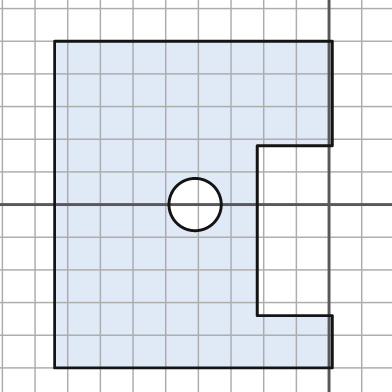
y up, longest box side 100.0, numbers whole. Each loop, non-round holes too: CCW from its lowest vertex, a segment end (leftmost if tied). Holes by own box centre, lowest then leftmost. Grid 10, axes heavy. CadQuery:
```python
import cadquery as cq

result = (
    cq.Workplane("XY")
    .moveTo(-84.0, -50.0)
    .lineTo(1.0, -50.0)
    .lineTo(1.0, -34.0)
    .lineTo(-22.0, -34.0)
    .lineTo(-22.0, 18.0)
    .lineTo(1.0, 18.0)
    .lineTo(1.0, 50.0)
    .lineTo(-84.0, 50.0)
    .close()
    .moveTo(-41.0, 0.0)
    .circle(8.0)
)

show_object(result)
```